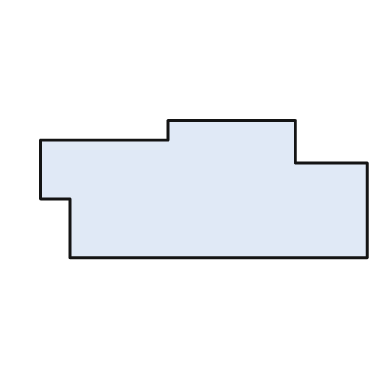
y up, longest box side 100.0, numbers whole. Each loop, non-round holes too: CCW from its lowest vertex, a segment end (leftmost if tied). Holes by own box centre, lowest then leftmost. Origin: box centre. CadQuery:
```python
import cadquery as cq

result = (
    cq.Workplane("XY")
    .moveTo(-41.0, -21.0)
    .lineTo(50.0, -21.0)
    .lineTo(50.0, 8.0)
    .lineTo(28.0, 8.0)
    .lineTo(28.0, 21.0)
    .lineTo(-11.0, 21.0)
    .lineTo(-11.0, 15.0)
    .lineTo(-50.0, 15.0)
    .lineTo(-50.0, -3.0)
    .lineTo(-41.0, -3.0)
    .close()
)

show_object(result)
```